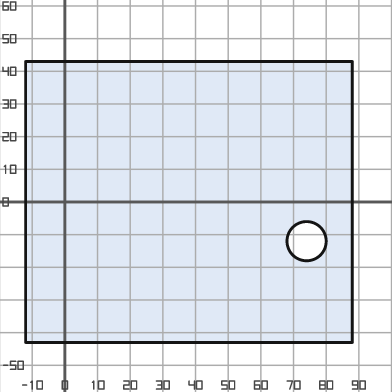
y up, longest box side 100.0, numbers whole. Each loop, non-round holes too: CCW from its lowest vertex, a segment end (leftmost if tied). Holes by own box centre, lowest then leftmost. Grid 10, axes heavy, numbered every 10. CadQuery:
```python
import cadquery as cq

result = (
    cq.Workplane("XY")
    .moveTo(-12.0, -43.0)
    .lineTo(88.0, -43.0)
    .lineTo(88.0, 43.0)
    .lineTo(-12.0, 43.0)
    .close()
    .moveTo(74.0, -12.0)
    .circle(6.0)
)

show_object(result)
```